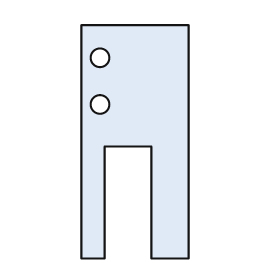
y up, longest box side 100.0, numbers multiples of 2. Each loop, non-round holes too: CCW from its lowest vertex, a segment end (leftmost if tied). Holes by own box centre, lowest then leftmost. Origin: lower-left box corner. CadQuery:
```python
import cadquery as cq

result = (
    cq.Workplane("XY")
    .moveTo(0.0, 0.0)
    .lineTo(10.0, 0.0)
    .lineTo(10.0, 48.0)
    .lineTo(30.0, 48.0)
    .lineTo(30.0, 0.0)
    .lineTo(46.0, 0.0)
    .lineTo(46.0, 100.0)
    .lineTo(0.0, 100.0)
    .close()
    .moveTo(8.0, 66.0)
    .circle(4.0)
    .moveTo(8.0, 86.0)
    .circle(4.0)
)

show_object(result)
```